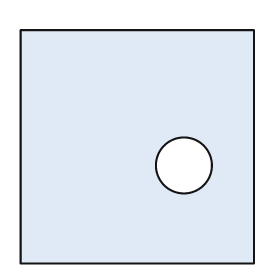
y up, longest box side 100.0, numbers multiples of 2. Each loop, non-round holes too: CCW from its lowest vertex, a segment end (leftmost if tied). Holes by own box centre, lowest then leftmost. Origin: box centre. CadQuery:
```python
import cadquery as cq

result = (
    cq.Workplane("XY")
    .moveTo(-50.0, -50.0)
    .lineTo(50.0, -50.0)
    .lineTo(50.0, 50.0)
    .lineTo(-50.0, 50.0)
    .close()
    .moveTo(20.0, -8.0)
    .circle(12.0)
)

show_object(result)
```